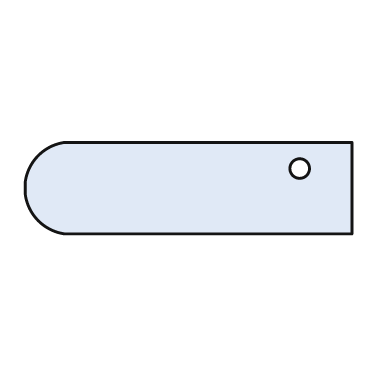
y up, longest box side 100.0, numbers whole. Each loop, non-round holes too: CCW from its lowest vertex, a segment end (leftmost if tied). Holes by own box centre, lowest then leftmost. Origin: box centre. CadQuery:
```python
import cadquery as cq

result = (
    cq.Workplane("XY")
    .moveTo(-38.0, -14.0)
    .lineTo(50.0, -14.0)
    .lineTo(50.0, 14.0)
    .lineTo(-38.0, 14.0)
    .threePointArc((-46.0, 10.0), (-50.0, 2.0))
    .lineTo(-50.0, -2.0)
    .threePointArc((-46.0, -10.0), (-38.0, -14.0))
    .close()
    .moveTo(34.0, 6.0)
    .circle(3.0)
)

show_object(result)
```